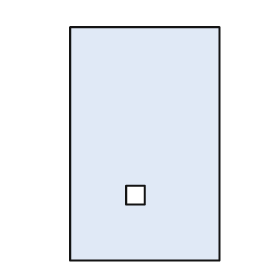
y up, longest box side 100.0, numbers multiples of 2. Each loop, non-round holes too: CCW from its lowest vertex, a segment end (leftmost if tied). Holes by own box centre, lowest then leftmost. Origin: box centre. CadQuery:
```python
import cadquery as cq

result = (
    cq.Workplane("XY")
    .moveTo(-32.0, -50.0)
    .lineTo(32.0, -50.0)
    .lineTo(32.0, 50.0)
    .lineTo(-32.0, 50.0)
    .close()
    .moveTo(-8.0, -26.0)
    .lineTo(0.0, -26.0)
    .lineTo(0.0, -18.0)
    .lineTo(-8.0, -18.0)
    .close()
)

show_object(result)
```